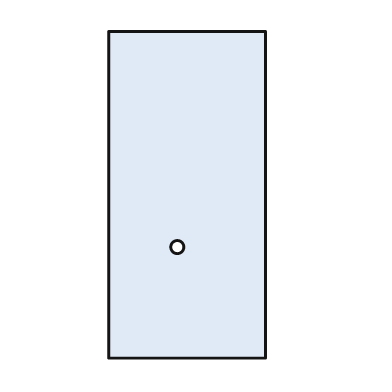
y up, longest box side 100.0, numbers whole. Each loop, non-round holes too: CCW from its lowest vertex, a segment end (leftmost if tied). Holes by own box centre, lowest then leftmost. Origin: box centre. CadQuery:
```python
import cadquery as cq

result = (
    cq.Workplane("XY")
    .moveTo(-24.0, -50.0)
    .lineTo(24.0, -50.0)
    .lineTo(24.0, 50.0)
    .lineTo(-24.0, 50.0)
    .close()
    .moveTo(-3.0, -16.0)
    .circle(2.0)
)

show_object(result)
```